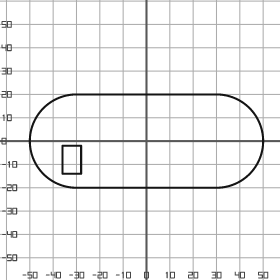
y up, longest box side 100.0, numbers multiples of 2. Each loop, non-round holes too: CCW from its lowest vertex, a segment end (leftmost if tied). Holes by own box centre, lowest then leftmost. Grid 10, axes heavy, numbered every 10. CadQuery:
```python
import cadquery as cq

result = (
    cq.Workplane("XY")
    .moveTo(-30.0, -20.0)
    .lineTo(30.0, -20.0)
    .threePointArc((50.0, 0.0), (30.0, 20.0))
    .lineTo(-30.0, 20.0)
    .threePointArc((-50.0, 0.0), (-30.0, -20.0))
    .close()
    .moveTo(-36.0, -14.0)
    .lineTo(-28.0, -14.0)
    .lineTo(-28.0, -2.0)
    .lineTo(-36.0, -2.0)
    .close()
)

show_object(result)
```